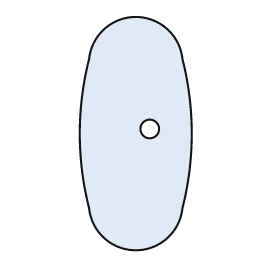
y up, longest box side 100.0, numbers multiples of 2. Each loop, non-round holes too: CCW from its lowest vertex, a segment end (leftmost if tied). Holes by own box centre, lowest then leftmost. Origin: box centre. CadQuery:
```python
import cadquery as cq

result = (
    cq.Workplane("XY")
    .moveTo(-20.0, -32.0)
    .threePointArc((0.0, -50.0), (20.0, -32.0))
    .threePointArc((24.0, 0.0), (20.0, 32.0))
    .threePointArc((0.0, 50.0), (-20.0, 32.0))
    .threePointArc((-24.0, 0.0), (-20.0, -32.0))
    .close()
    .moveTo(6.0, 2.0)
    .circle(4.0)
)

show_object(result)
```